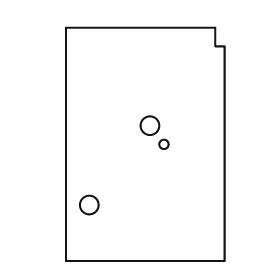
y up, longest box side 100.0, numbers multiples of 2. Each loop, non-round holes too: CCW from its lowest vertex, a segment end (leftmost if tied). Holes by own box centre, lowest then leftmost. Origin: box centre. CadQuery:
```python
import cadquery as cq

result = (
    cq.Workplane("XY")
    .moveTo(-34.0, -50.0)
    .lineTo(34.0, -50.0)
    .lineTo(34.0, 42.0)
    .lineTo(30.0, 42.0)
    .lineTo(30.0, 50.0)
    .lineTo(-34.0, 50.0)
    .close()
    .moveTo(-24.0, -26.0)
    .circle(4.0)
    .moveTo(8.0, 0.0)
    .circle(2.0)
    .moveTo(2.0, 8.0)
    .circle(4.0)
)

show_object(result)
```